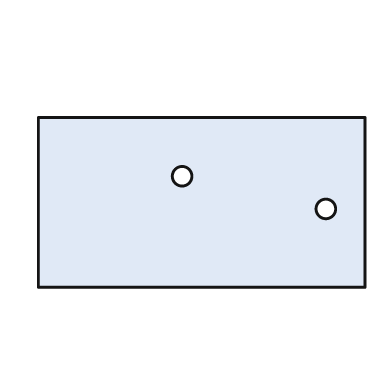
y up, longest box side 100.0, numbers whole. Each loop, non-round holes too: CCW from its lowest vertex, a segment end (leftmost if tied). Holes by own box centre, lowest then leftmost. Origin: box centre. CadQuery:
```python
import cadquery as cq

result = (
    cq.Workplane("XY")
    .moveTo(-50.0, -26.0)
    .lineTo(50.0, -26.0)
    .lineTo(50.0, 26.0)
    .lineTo(-50.0, 26.0)
    .close()
    .moveTo(38.0, -2.0)
    .circle(3.0)
    .moveTo(-6.0, 8.0)
    .circle(3.0)
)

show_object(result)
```